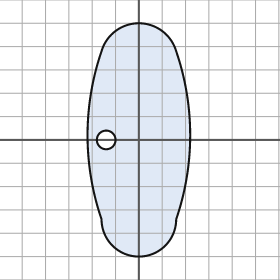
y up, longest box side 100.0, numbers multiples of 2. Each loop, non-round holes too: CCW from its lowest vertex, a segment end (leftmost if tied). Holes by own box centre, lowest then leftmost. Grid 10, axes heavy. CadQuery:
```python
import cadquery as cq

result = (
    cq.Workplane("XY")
    .moveTo(-16.0, -34.0)
    .threePointArc((0.0, -50.0), (16.0, -34.0))
    .threePointArc((22.0, 2.0), (16.0, 38.0))
    .threePointArc((0.0, 50.0), (-16.0, 38.0))
    .threePointArc((-22.0, 2.0), (-16.0, -34.0))
    .close()
    .moveTo(-14.0, 0.0)
    .circle(4.0)
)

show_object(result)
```